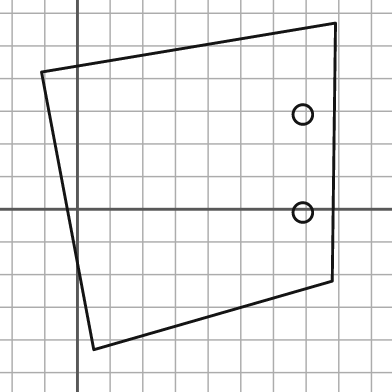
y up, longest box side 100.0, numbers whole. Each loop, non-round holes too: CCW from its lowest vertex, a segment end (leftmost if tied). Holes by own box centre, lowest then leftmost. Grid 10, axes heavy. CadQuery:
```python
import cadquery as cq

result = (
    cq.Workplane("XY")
    .moveTo(5.0, -43.0)
    .lineTo(78.0, -22.0)
    .lineTo(79.0, 57.0)
    .lineTo(-11.0, 42.0)
    .close()
    .moveTo(69.0, -1.0)
    .circle(3.0)
    .moveTo(69.0, 29.0)
    .circle(3.0)
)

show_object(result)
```